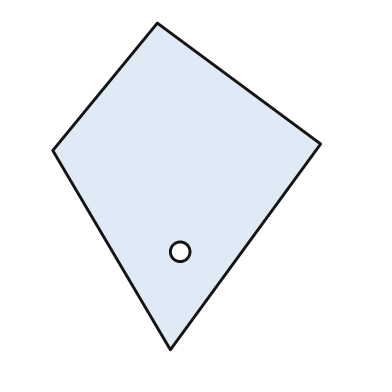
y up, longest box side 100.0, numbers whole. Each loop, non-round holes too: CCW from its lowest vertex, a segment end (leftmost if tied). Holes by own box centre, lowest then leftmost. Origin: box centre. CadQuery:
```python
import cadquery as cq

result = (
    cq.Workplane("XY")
    .moveTo(-5.0, -50.0)
    .lineTo(41.0, 13.0)
    .lineTo(-9.0, 50.0)
    .lineTo(-41.0, 11.0)
    .close()
    .moveTo(-2.0, -20.0)
    .circle(3.0)
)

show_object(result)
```